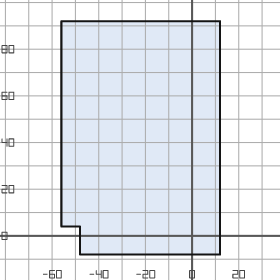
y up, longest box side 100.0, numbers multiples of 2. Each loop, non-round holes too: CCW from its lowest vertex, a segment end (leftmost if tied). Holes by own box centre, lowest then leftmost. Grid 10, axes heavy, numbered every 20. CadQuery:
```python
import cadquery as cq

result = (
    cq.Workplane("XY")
    .moveTo(-48.0, -8.0)
    .lineTo(12.0, -8.0)
    .lineTo(12.0, 92.0)
    .lineTo(-56.0, 92.0)
    .lineTo(-56.0, 4.0)
    .lineTo(-48.0, 4.0)
    .close()
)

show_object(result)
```